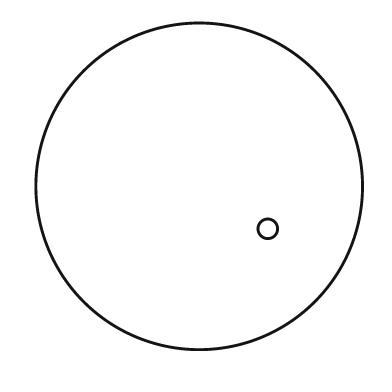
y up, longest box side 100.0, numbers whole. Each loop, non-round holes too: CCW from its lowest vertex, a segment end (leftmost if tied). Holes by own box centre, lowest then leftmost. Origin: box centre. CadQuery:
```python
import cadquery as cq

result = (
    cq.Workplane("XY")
    .moveTo(0.0, 0.0)
    .circle(50.0)
    .moveTo(21.0, -13.0)
    .circle(3.0)
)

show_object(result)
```